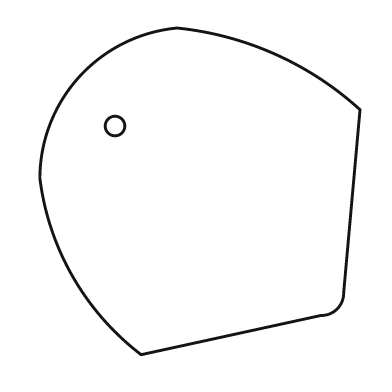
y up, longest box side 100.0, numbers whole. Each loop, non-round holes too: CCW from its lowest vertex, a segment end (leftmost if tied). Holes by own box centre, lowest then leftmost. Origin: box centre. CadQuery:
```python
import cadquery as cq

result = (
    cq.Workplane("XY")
    .moveTo(-18.0, -50.0)
    .lineTo(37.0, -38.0)
    .threePointArc((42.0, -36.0), (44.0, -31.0))
    .lineTo(49.0, 25.0)
    .threePointArc((23.0, 42.0), (-7.0, 50.0))
    .threePointArc((-37.0, 35.0), (-49.0, 4.0))
    .threePointArc((-39.0, -26.0), (-18.0, -50.0))
    .close()
    .moveTo(-26.0, 20.0)
    .circle(3.0)
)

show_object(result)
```